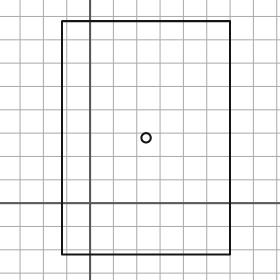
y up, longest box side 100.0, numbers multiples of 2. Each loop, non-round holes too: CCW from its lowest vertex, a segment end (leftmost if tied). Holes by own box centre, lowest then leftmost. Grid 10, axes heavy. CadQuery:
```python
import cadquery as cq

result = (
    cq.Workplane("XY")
    .moveTo(-12.0, -22.0)
    .lineTo(60.0, -22.0)
    .lineTo(60.0, 78.0)
    .lineTo(-12.0, 78.0)
    .close()
    .moveTo(24.0, 28.0)
    .circle(2.0)
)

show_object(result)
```